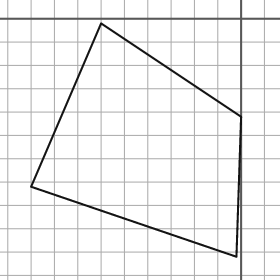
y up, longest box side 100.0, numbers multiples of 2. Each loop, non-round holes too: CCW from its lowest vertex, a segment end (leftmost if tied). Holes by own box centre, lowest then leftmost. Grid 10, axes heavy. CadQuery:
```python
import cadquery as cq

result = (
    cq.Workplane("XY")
    .moveTo(-2.0, -102.0)
    .lineTo(0.0, -42.0)
    .lineTo(-60.0, -2.0)
    .lineTo(-90.0, -72.0)
    .close()
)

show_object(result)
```